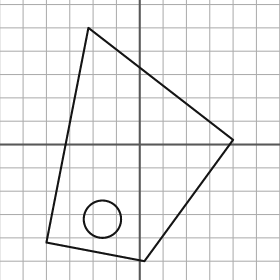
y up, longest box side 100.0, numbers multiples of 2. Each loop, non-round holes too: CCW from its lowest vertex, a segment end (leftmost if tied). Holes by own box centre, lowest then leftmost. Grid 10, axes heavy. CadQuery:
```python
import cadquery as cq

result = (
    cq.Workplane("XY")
    .moveTo(2.0, -50.0)
    .lineTo(40.0, 2.0)
    .lineTo(-22.0, 50.0)
    .lineTo(-40.0, -42.0)
    .close()
    .moveTo(-16.0, -32.0)
    .circle(8.0)
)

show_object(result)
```